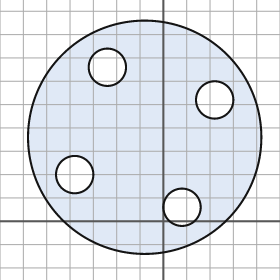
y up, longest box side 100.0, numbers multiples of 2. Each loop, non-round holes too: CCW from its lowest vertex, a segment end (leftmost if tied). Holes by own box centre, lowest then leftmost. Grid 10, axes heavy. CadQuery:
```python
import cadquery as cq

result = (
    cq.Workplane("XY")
    .moveTo(-8.0, 36.0)
    .circle(50.0)
    .moveTo(8.0, 6.0)
    .circle(8.0)
    .moveTo(-38.0, 20.0)
    .circle(8.0)
    .moveTo(22.0, 52.0)
    .circle(8.0)
    .moveTo(-24.0, 66.0)
    .circle(8.0)
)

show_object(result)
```